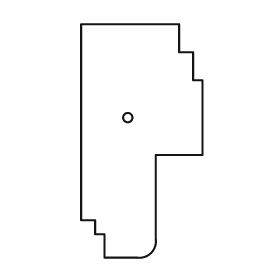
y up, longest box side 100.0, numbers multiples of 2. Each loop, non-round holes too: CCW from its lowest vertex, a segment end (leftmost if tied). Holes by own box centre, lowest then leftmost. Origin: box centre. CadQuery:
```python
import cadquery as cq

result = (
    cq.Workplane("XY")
    .moveTo(-16.0, -50.0)
    .lineTo(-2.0, -50.0)
    .threePointArc((4.0, -48.0), (6.0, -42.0))
    .lineTo(6.0, -6.0)
    .lineTo(26.0, -6.0)
    .lineTo(26.0, 26.0)
    .lineTo(22.0, 26.0)
    .lineTo(22.0, 38.0)
    .lineTo(16.0, 38.0)
    .lineTo(16.0, 50.0)
    .lineTo(-26.0, 50.0)
    .lineTo(-26.0, -34.0)
    .lineTo(-20.0, -34.0)
    .lineTo(-20.0, -40.0)
    .lineTo(-16.0, -40.0)
    .close()
    .moveTo(-6.0, 10.0)
    .circle(2.0)
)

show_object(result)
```